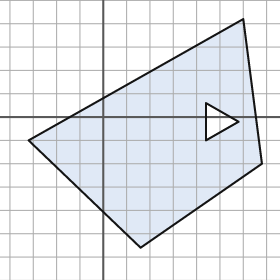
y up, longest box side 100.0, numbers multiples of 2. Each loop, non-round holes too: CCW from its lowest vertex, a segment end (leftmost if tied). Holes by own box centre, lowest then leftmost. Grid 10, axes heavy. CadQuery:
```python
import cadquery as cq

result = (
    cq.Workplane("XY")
    .moveTo(16.0, -56.0)
    .lineTo(68.0, -20.0)
    .lineTo(60.0, 42.0)
    .lineTo(-32.0, -10.0)
    .close()
    .moveTo(44.0, -10.0)
    .lineTo(58.0, -2.0)
    .lineTo(44.0, 6.0)
    .close()
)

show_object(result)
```